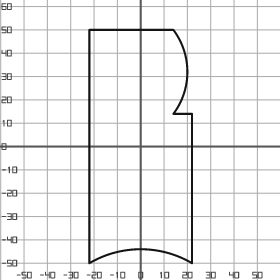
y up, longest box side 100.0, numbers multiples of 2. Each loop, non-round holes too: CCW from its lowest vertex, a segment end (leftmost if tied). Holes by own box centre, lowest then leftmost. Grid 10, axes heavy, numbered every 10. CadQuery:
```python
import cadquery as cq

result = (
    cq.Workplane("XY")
    .moveTo(-22.0, -50.0)
    .threePointArc((0.0, -44.0), (22.0, -50.0))
    .lineTo(22.0, 14.0)
    .lineTo(14.0, 14.0)
    .threePointArc((20.0, 32.0), (14.0, 50.0))
    .lineTo(-22.0, 50.0)
    .close()
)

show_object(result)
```